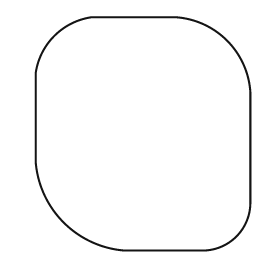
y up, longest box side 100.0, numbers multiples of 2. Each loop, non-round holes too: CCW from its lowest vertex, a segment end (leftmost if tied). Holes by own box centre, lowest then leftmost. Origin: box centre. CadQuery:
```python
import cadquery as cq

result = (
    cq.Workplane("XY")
    .moveTo(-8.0, -50.0)
    .lineTo(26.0, -50.0)
    .threePointArc((40.0, -44.0), (46.0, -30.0))
    .lineTo(46.0, 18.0)
    .threePointArc((36.0, 40.0), (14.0, 50.0))
    .lineTo(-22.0, 50.0)
    .threePointArc((-38.0, 42.0), (-46.0, 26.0))
    .lineTo(-46.0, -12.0)
    .threePointArc((-34.0, -38.0), (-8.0, -50.0))
    .close()
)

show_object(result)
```